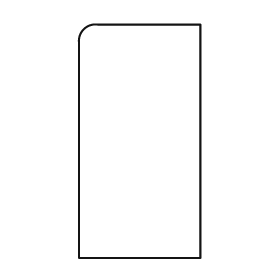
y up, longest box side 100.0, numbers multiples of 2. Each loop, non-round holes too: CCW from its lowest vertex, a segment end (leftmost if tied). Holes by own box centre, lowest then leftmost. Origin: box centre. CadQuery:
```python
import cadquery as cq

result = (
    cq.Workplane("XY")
    .moveTo(-26.0, -50.0)
    .lineTo(26.0, -50.0)
    .lineTo(26.0, 50.0)
    .lineTo(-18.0, 50.0)
    .threePointArc((-24.0, 48.0), (-26.0, 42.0))
    .close()
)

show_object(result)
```